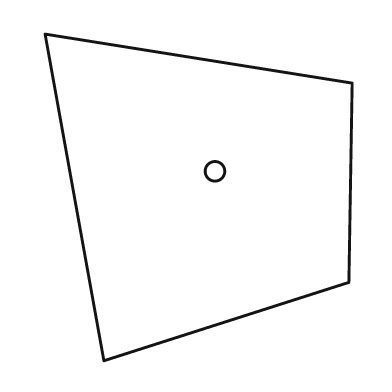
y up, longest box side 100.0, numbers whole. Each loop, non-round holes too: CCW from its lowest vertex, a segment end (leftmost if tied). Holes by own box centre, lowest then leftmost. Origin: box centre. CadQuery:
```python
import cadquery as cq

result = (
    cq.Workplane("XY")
    .moveTo(-29.0, -50.0)
    .lineTo(46.0, -26.0)
    .lineTo(47.0, 35.0)
    .lineTo(-47.0, 50.0)
    .close()
    .moveTo(5.0, 8.0)
    .circle(3.0)
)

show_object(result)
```